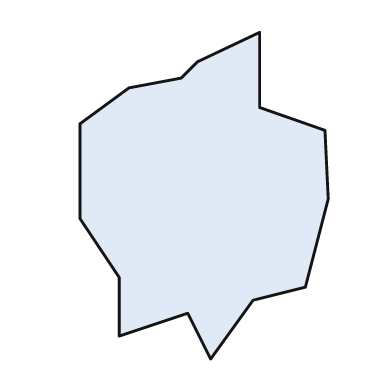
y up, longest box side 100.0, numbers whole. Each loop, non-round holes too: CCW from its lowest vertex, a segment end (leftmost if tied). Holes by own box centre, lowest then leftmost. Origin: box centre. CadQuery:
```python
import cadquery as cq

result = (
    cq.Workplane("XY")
    .moveTo(2.0, -50.0)
    .lineTo(15.0, -32.0)
    .lineTo(31.0, -28.0)
    .lineTo(38.0, -1.0)
    .lineTo(37.0, 20.0)
    .lineTo(17.0, 27.0)
    .lineTo(17.0, 50.0)
    .lineTo(-2.0, 41.0)
    .lineTo(-7.0, 36.0)
    .lineTo(-23.0, 33.0)
    .lineTo(-38.0, 22.0)
    .lineTo(-38.0, -7.0)
    .lineTo(-26.0, -25.0)
    .lineTo(-26.0, -43.0)
    .lineTo(-5.0, -36.0)
    .close()
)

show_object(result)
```